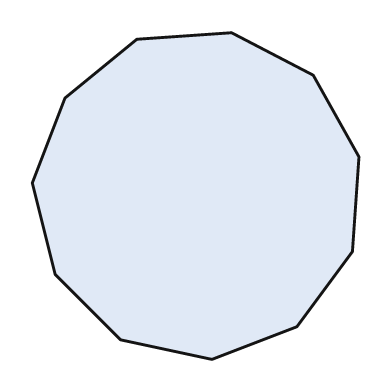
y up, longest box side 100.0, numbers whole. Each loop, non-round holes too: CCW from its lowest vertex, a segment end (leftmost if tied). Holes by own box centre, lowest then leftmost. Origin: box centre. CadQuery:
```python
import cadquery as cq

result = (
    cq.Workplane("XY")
    .moveTo(5.0, -50.0)
    .lineTo(31.0, -40.0)
    .lineTo(48.0, -17.0)
    .lineTo(50.0, 12.0)
    .lineTo(36.0, 37.0)
    .lineTo(11.0, 50.0)
    .lineTo(-18.0, 48.0)
    .lineTo(-40.0, 30.0)
    .lineTo(-50.0, 4.0)
    .lineTo(-43.0, -24.0)
    .lineTo(-23.0, -44.0)
    .close()
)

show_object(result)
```